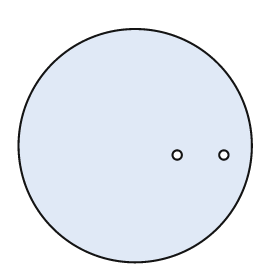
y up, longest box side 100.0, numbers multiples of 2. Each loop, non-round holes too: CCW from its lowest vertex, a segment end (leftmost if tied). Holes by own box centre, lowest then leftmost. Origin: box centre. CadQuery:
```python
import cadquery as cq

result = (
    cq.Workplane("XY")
    .moveTo(0.0, 0.0)
    .circle(50.0)
    .moveTo(18.0, -4.0)
    .circle(2.0)
    .moveTo(38.0, -4.0)
    .circle(2.0)
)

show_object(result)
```